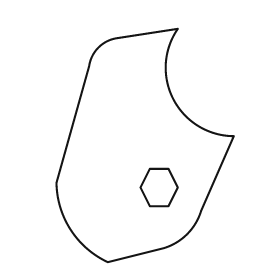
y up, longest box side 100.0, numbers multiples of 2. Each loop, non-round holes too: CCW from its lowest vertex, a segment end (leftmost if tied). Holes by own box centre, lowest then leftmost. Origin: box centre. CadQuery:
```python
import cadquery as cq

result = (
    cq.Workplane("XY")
    .moveTo(-16.0, -50.0)
    .lineTo(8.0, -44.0)
    .threePointArc((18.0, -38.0), (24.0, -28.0))
    .lineTo(38.0, 4.0)
    .threePointArc((12.0, 20.0), (14.0, 50.0))
    .lineTo(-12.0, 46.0)
    .threePointArc((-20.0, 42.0), (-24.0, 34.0))
    .lineTo(-38.0, -16.0)
    .threePointArc((-32.0, -36.0), (-16.0, -50.0))
    .close()
    .moveTo(2.0, -26.0)
    .lineTo(10.0, -26.0)
    .lineTo(14.0, -18.0)
    .lineTo(10.0, -10.0)
    .lineTo(2.0, -10.0)
    .lineTo(-2.0, -18.0)
    .close()
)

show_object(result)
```